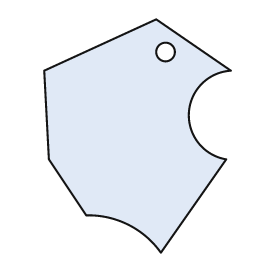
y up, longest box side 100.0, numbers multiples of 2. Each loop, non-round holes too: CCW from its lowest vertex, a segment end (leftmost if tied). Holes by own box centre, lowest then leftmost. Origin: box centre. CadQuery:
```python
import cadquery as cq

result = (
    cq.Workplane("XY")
    .moveTo(10.0, -50.0)
    .lineTo(38.0, -10.0)
    .threePointArc((22.0, 10.0), (40.0, 28.0))
    .lineTo(8.0, 50.0)
    .lineTo(-40.0, 28.0)
    .lineTo(-38.0, -10.0)
    .lineTo(-22.0, -34.0)
    .threePointArc((-4.0, -38.0), (10.0, -50.0))
    .close()
    .moveTo(12.0, 36.0)
    .circle(4.0)
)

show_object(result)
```